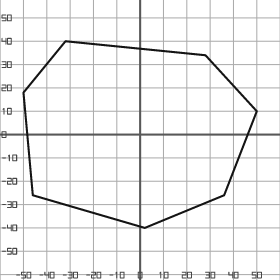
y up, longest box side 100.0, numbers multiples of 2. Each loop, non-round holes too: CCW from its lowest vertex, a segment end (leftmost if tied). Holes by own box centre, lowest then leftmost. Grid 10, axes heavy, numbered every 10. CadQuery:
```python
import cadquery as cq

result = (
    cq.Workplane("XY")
    .moveTo(2.0, -40.0)
    .lineTo(36.0, -26.0)
    .lineTo(50.0, 10.0)
    .lineTo(28.0, 34.0)
    .lineTo(-32.0, 40.0)
    .lineTo(-50.0, 18.0)
    .lineTo(-46.0, -26.0)
    .close()
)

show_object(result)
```